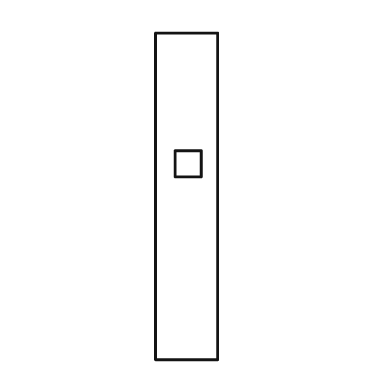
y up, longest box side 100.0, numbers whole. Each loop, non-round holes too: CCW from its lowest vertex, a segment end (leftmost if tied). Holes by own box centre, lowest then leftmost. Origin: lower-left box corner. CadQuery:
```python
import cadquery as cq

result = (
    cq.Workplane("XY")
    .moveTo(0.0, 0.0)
    .lineTo(19.0, 0.0)
    .lineTo(19.0, 100.0)
    .lineTo(0.0, 100.0)
    .close()
    .moveTo(6.0, 56.0)
    .lineTo(14.0, 56.0)
    .lineTo(14.0, 64.0)
    .lineTo(6.0, 64.0)
    .close()
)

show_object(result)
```